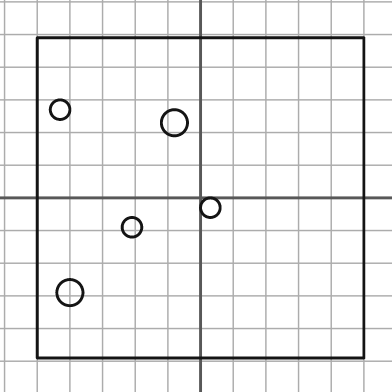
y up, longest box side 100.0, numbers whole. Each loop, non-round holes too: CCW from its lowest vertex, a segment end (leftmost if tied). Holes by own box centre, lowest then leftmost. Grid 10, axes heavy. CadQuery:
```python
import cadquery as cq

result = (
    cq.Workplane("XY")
    .moveTo(-50.0, -49.0)
    .lineTo(50.0, -49.0)
    .lineTo(50.0, 49.0)
    .lineTo(-50.0, 49.0)
    .close()
    .moveTo(-40.0, -29.0)
    .circle(4.0)
    .moveTo(-21.0, -9.0)
    .circle(3.0)
    .moveTo(3.0, -3.0)
    .circle(3.0)
    .moveTo(-8.0, 23.0)
    .circle(4.0)
    .moveTo(-43.0, 27.0)
    .circle(3.0)
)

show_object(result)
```